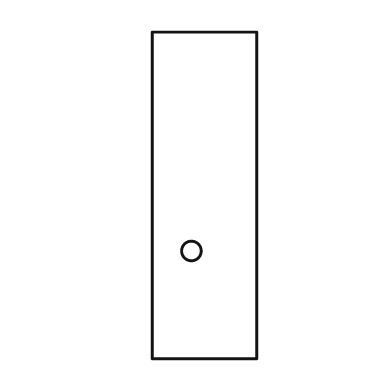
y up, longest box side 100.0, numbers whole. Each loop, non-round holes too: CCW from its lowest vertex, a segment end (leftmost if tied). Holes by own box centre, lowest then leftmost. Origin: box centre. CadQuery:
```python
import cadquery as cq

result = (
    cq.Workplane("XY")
    .moveTo(-16.0, -50.0)
    .lineTo(16.0, -50.0)
    .lineTo(16.0, 50.0)
    .lineTo(-16.0, 50.0)
    .close()
    .moveTo(-4.0, -17.0)
    .circle(3.0)
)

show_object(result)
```